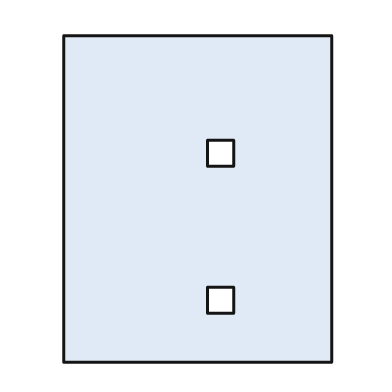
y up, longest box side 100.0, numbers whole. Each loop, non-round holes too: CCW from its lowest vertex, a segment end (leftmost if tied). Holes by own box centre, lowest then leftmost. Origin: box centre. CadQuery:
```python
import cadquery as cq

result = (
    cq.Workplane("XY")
    .moveTo(-41.0, -50.0)
    .lineTo(41.0, -50.0)
    .lineTo(41.0, 50.0)
    .lineTo(-41.0, 50.0)
    .close()
    .moveTo(3.0, -35.0)
    .lineTo(11.0, -35.0)
    .lineTo(11.0, -27.0)
    .lineTo(3.0, -27.0)
    .close()
    .moveTo(3.0, 10.0)
    .lineTo(11.0, 10.0)
    .lineTo(11.0, 18.0)
    .lineTo(3.0, 18.0)
    .close()
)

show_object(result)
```